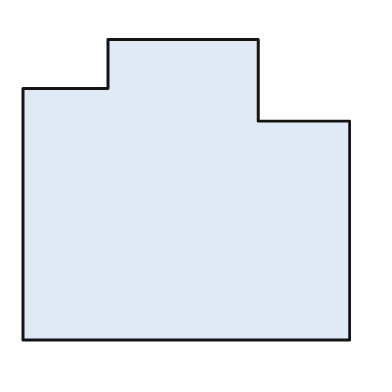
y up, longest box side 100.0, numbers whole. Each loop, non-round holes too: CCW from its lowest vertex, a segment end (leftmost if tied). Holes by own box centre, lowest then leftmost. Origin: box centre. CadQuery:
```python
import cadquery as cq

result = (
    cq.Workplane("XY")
    .moveTo(-50.0, -46.0)
    .lineTo(50.0, -46.0)
    .lineTo(50.0, 21.0)
    .lineTo(22.0, 21.0)
    .lineTo(22.0, 46.0)
    .lineTo(-24.0, 46.0)
    .lineTo(-24.0, 31.0)
    .lineTo(-50.0, 31.0)
    .close()
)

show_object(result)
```